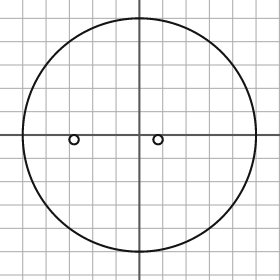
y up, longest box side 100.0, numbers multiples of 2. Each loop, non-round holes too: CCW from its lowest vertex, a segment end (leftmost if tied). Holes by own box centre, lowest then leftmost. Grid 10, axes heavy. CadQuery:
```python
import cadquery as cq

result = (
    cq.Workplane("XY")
    .moveTo(0.0, 0.0)
    .circle(50.0)
    .moveTo(-28.0, -2.0)
    .circle(2.0)
    .moveTo(8.0, -2.0)
    .circle(2.0)
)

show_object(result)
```